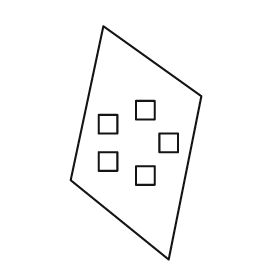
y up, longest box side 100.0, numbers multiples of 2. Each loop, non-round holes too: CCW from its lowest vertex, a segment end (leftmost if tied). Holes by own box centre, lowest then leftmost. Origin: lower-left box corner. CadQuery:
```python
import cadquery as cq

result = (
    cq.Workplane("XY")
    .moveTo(42.0, 0.0)
    .lineTo(56.0, 70.0)
    .lineTo(14.0, 100.0)
    .lineTo(0.0, 34.0)
    .close()
    .moveTo(28.0, 32.0)
    .lineTo(36.0, 32.0)
    .lineTo(36.0, 40.0)
    .lineTo(28.0, 40.0)
    .close()
    .moveTo(12.0, 38.0)
    .lineTo(20.0, 38.0)
    .lineTo(20.0, 46.0)
    .lineTo(12.0, 46.0)
    .close()
    .moveTo(38.0, 46.0)
    .lineTo(46.0, 46.0)
    .lineTo(46.0, 54.0)
    .lineTo(38.0, 54.0)
    .close()
    .moveTo(12.0, 54.0)
    .lineTo(20.0, 54.0)
    .lineTo(20.0, 62.0)
    .lineTo(12.0, 62.0)
    .close()
    .moveTo(28.0, 60.0)
    .lineTo(36.0, 60.0)
    .lineTo(36.0, 68.0)
    .lineTo(28.0, 68.0)
    .close()
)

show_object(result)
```